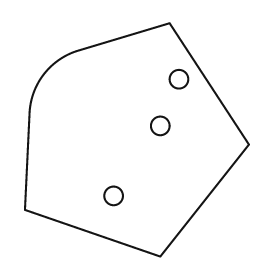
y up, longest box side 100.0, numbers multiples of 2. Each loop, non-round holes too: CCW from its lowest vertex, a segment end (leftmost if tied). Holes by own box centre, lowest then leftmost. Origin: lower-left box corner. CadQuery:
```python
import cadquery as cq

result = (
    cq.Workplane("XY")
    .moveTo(58.0, 0.0)
    .lineTo(96.0, 48.0)
    .lineTo(62.0, 100.0)
    .lineTo(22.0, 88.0)
    .threePointArc((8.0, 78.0), (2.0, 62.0))
    .lineTo(0.0, 20.0)
    .close()
    .moveTo(38.0, 26.0)
    .circle(4.0)
    .moveTo(58.0, 56.0)
    .circle(4.0)
    .moveTo(66.0, 76.0)
    .circle(4.0)
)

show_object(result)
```